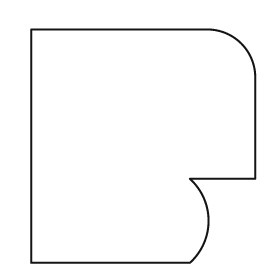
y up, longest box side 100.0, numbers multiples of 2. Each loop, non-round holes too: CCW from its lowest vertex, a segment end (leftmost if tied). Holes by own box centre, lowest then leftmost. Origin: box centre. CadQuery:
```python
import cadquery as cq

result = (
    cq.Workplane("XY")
    .moveTo(-48.0, -50.0)
    .lineTo(20.0, -50.0)
    .threePointArc((28.0, -32.0), (20.0, -14.0))
    .lineTo(48.0, -14.0)
    .lineTo(48.0, 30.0)
    .threePointArc((42.0, 44.0), (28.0, 50.0))
    .lineTo(-48.0, 50.0)
    .close()
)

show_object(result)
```